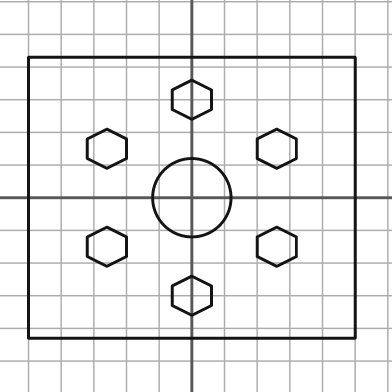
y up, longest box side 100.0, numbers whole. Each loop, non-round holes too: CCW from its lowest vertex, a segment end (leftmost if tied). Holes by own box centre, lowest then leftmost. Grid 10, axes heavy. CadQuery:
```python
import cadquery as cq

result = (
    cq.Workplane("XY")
    .moveTo(-50.0, -43.0)
    .lineTo(50.0, -43.0)
    .lineTo(50.0, 43.0)
    .lineTo(-50.0, 43.0)
    .close()
    .moveTo(0.0, -36.0)
    .lineTo(6.0, -33.0)
    .lineTo(6.0, -27.0)
    .lineTo(0.0, -24.0)
    .lineTo(-6.0, -27.0)
    .lineTo(-6.0, -33.0)
    .close()
    .moveTo(-26.0, -21.0)
    .lineTo(-20.0, -18.0)
    .lineTo(-20.0, -12.0)
    .lineTo(-26.0, -9.0)
    .lineTo(-32.0, -12.0)
    .lineTo(-32.0, -18.0)
    .close()
    .moveTo(26.0, -21.0)
    .lineTo(32.0, -18.0)
    .lineTo(32.0, -12.0)
    .lineTo(26.0, -9.0)
    .lineTo(20.0, -12.0)
    .lineTo(20.0, -18.0)
    .close()
    .moveTo(0.0, 0.0)
    .circle(12.0)
    .moveTo(-26.0, 9.0)
    .lineTo(-20.0, 12.0)
    .lineTo(-20.0, 18.0)
    .lineTo(-26.0, 21.0)
    .lineTo(-32.0, 18.0)
    .lineTo(-32.0, 12.0)
    .close()
    .moveTo(26.0, 9.0)
    .lineTo(32.0, 12.0)
    .lineTo(32.0, 18.0)
    .lineTo(26.0, 21.0)
    .lineTo(20.0, 18.0)
    .lineTo(20.0, 12.0)
    .close()
    .moveTo(0.0, 24.0)
    .lineTo(6.0, 27.0)
    .lineTo(6.0, 33.0)
    .lineTo(0.0, 36.0)
    .lineTo(-6.0, 33.0)
    .lineTo(-6.0, 27.0)
    .close()
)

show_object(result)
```